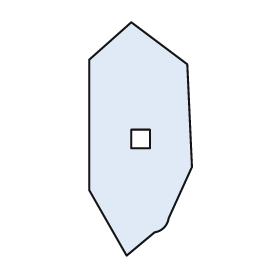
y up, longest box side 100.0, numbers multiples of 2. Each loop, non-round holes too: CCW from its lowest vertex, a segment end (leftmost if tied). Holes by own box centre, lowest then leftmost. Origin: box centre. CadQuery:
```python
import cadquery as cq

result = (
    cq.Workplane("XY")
    .moveTo(-6.0, -50.0)
    .lineTo(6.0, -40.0)
    .threePointArc((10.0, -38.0), (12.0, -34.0))
    .lineTo(22.0, -12.0)
    .lineTo(20.0, 32.0)
    .lineTo(-4.0, 50.0)
    .lineTo(-22.0, 34.0)
    .lineTo(-22.0, -22.0)
    .close()
    .moveTo(-4.0, -4.0)
    .lineTo(4.0, -4.0)
    .lineTo(4.0, 4.0)
    .lineTo(-4.0, 4.0)
    .close()
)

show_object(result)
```